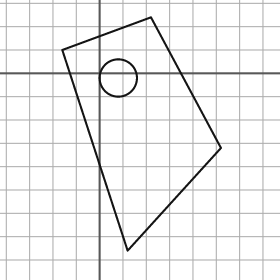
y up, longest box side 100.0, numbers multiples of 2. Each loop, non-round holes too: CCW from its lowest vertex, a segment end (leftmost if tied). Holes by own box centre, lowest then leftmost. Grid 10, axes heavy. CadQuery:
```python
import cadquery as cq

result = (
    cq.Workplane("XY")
    .moveTo(12.0, -76.0)
    .lineTo(52.0, -32.0)
    .lineTo(22.0, 24.0)
    .lineTo(-16.0, 10.0)
    .close()
    .moveTo(8.0, -2.0)
    .circle(8.0)
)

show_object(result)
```